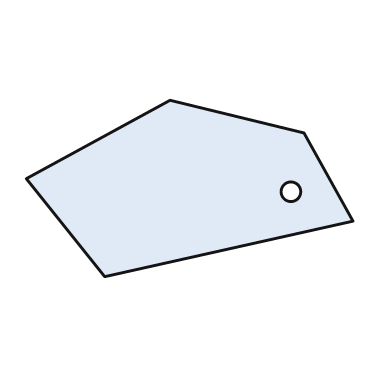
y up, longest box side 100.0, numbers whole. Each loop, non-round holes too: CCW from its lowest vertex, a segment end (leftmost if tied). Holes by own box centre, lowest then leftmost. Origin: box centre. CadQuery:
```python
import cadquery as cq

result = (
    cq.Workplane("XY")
    .moveTo(-26.0, -27.0)
    .lineTo(50.0, -10.0)
    .lineTo(35.0, 17.0)
    .lineTo(-6.0, 27.0)
    .lineTo(-50.0, 3.0)
    .close()
    .moveTo(31.0, -1.0)
    .circle(3.0)
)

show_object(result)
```